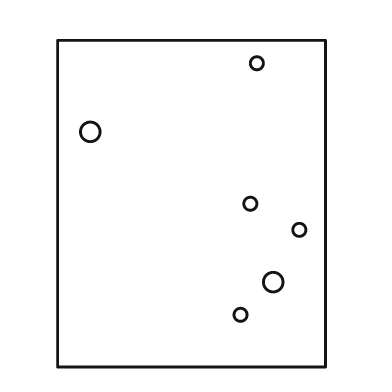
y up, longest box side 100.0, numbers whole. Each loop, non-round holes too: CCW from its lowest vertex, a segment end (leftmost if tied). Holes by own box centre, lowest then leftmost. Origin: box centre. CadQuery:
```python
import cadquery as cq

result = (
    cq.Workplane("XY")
    .moveTo(-41.0, -50.0)
    .lineTo(41.0, -50.0)
    .lineTo(41.0, 50.0)
    .lineTo(-41.0, 50.0)
    .close()
    .moveTo(15.0, -34.0)
    .circle(2.0)
    .moveTo(25.0, -24.0)
    .circle(3.0)
    .moveTo(33.0, -8.0)
    .circle(2.0)
    .moveTo(18.0, 0.0)
    .circle(2.0)
    .moveTo(-31.0, 22.0)
    .circle(3.0)
    .moveTo(20.0, 43.0)
    .circle(2.0)
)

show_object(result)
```